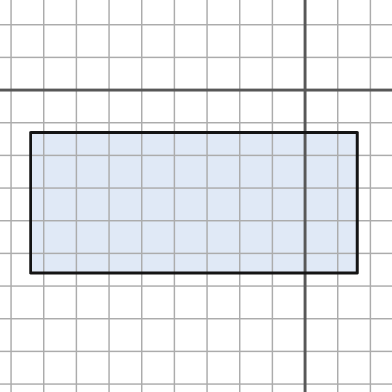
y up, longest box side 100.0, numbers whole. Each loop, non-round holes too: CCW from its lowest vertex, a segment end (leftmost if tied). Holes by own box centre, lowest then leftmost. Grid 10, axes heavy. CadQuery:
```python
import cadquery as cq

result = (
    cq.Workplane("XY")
    .moveTo(-84.0, -56.0)
    .lineTo(16.0, -56.0)
    .lineTo(16.0, -13.0)
    .lineTo(-84.0, -13.0)
    .close()
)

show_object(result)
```